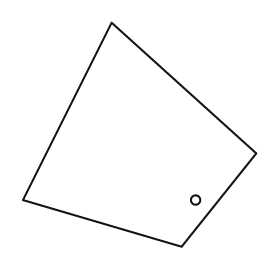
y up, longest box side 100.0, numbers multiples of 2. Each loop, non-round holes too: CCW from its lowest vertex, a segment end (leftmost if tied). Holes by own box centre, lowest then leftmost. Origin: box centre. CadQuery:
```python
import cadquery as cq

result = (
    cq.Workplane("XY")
    .moveTo(18.0, -48.0)
    .lineTo(50.0, -8.0)
    .lineTo(-12.0, 48.0)
    .lineTo(-50.0, -28.0)
    .close()
    .moveTo(24.0, -28.0)
    .circle(2.0)
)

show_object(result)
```